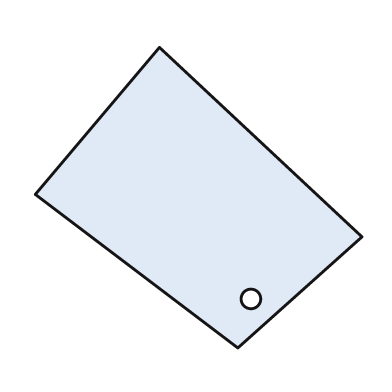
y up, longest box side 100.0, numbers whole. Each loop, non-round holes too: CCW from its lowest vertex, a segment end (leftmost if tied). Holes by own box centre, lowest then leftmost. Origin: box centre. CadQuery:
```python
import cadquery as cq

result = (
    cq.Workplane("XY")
    .moveTo(12.0, -46.0)
    .lineTo(50.0, -12.0)
    .lineTo(-12.0, 46.0)
    .lineTo(-50.0, 1.0)
    .close()
    .moveTo(16.0, -31.0)
    .circle(3.0)
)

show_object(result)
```